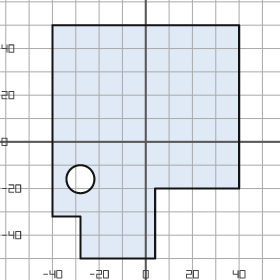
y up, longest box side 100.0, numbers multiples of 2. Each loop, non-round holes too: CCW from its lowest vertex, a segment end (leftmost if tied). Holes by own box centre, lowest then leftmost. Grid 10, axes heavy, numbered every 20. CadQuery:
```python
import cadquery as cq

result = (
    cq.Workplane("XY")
    .moveTo(-28.0, -50.0)
    .lineTo(4.0, -50.0)
    .lineTo(4.0, -20.0)
    .lineTo(40.0, -20.0)
    .lineTo(40.0, 50.0)
    .lineTo(-40.0, 50.0)
    .lineTo(-40.0, -32.0)
    .lineTo(-28.0, -32.0)
    .close()
    .moveTo(-28.0, -16.0)
    .circle(6.0)
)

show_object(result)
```